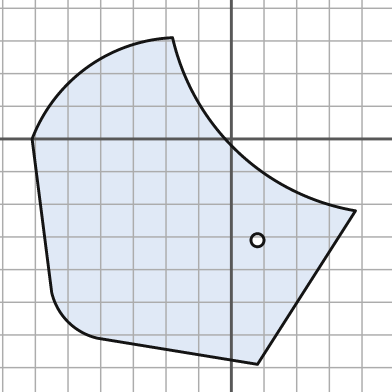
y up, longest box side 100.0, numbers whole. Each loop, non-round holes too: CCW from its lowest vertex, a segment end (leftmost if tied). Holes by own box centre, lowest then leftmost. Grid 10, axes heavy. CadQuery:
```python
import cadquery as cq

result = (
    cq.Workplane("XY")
    .moveTo(8.0, -69.0)
    .lineTo(38.0, -22.0)
    .threePointArc((2.0, -4.0), (-18.0, 31.0))
    .threePointArc((-44.0, 22.0), (-61.0, 0.0))
    .lineTo(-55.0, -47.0)
    .threePointArc((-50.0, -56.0), (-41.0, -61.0))
    .close()
    .moveTo(8.0, -31.0)
    .circle(2.0)
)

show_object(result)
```